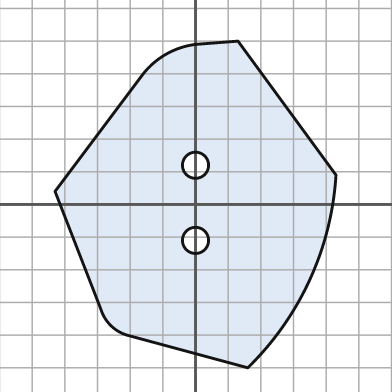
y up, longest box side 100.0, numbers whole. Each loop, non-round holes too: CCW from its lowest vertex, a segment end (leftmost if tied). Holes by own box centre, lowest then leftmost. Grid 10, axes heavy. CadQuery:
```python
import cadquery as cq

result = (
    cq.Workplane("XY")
    .moveTo(16.0, -50.0)
    .threePointArc((35.0, -23.0), (43.0, 9.0))
    .lineTo(13.0, 50.0)
    .lineTo(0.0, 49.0)
    .threePointArc((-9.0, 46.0), (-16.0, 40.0))
    .lineTo(-43.0, 4.0)
    .lineTo(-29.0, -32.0)
    .threePointArc((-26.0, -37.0), (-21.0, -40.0))
    .close()
    .moveTo(0.0, -11.0)
    .circle(4.0)
    .moveTo(0.0, 12.0)
    .circle(4.0)
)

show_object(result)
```